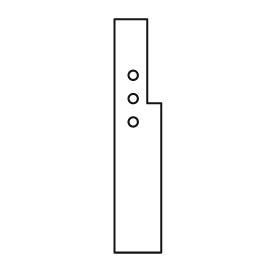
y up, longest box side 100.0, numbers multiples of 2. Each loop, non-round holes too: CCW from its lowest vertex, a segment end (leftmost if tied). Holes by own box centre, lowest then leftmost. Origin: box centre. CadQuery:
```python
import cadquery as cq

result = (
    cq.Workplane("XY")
    .moveTo(-10.0, -50.0)
    .lineTo(10.0, -50.0)
    .lineTo(10.0, 14.0)
    .lineTo(4.0, 14.0)
    .lineTo(4.0, 50.0)
    .lineTo(-10.0, 50.0)
    .close()
    .moveTo(-2.0, 6.0)
    .circle(2.0)
    .moveTo(-2.0, 16.0)
    .circle(2.0)
    .moveTo(-2.0, 26.0)
    .circle(2.0)
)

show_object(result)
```